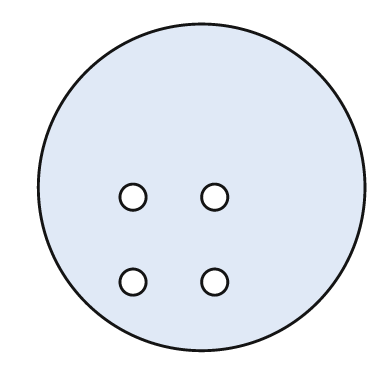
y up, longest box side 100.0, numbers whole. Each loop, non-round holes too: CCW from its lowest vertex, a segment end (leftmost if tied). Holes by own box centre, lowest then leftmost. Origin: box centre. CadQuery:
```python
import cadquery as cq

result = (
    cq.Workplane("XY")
    .moveTo(0.0, 0.0)
    .circle(50.0)
    .moveTo(-21.0, -29.0)
    .circle(4.0)
    .moveTo(4.0, -29.0)
    .circle(4.0)
    .moveTo(-21.0, -3.0)
    .circle(4.0)
    .moveTo(4.0, -3.0)
    .circle(4.0)
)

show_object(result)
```